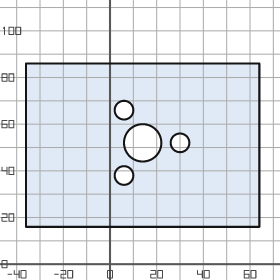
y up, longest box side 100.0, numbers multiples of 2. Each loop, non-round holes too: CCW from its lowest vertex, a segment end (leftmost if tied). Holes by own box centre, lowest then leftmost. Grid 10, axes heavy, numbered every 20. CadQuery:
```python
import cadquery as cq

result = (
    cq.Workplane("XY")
    .moveTo(-36.0, 16.0)
    .lineTo(64.0, 16.0)
    .lineTo(64.0, 86.0)
    .lineTo(-36.0, 86.0)
    .close()
    .moveTo(6.0, 38.0)
    .circle(4.0)
    .moveTo(14.0, 52.0)
    .circle(8.0)
    .moveTo(30.0, 52.0)
    .circle(4.0)
    .moveTo(6.0, 66.0)
    .circle(4.0)
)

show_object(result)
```